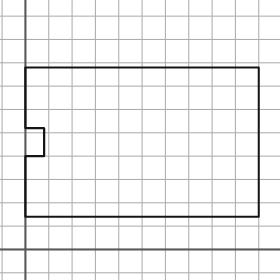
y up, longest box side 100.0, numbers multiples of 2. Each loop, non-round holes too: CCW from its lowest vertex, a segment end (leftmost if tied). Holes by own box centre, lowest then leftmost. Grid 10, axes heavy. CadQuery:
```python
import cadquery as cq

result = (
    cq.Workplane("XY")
    .moveTo(0.0, 14.0)
    .lineTo(100.0, 14.0)
    .lineTo(100.0, 78.0)
    .lineTo(0.0, 78.0)
    .lineTo(0.0, 52.0)
    .lineTo(8.0, 52.0)
    .lineTo(8.0, 40.0)
    .lineTo(0.0, 40.0)
    .close()
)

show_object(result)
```